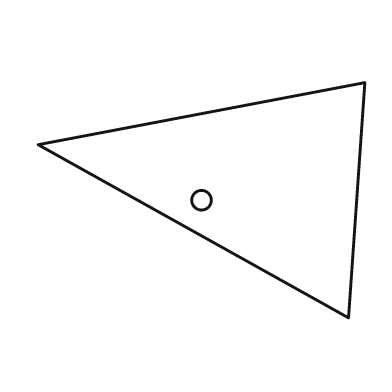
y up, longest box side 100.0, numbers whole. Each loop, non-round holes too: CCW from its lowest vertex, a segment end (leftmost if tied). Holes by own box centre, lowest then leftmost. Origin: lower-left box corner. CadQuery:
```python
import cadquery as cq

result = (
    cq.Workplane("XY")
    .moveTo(95.0, 0.0)
    .lineTo(100.0, 72.0)
    .lineTo(0.0, 53.0)
    .close()
    .moveTo(50.0, 36.0)
    .circle(3.0)
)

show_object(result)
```